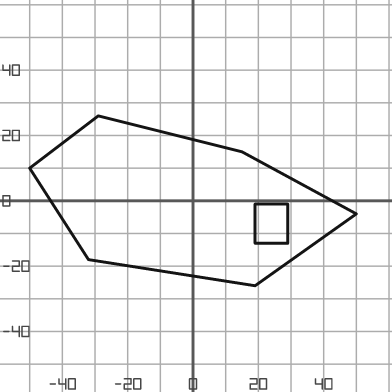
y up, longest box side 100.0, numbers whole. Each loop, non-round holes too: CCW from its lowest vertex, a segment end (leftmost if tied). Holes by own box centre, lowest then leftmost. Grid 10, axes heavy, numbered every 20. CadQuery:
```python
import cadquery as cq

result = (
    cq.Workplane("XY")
    .moveTo(19.0, -26.0)
    .lineTo(50.0, -4.0)
    .lineTo(15.0, 15.0)
    .lineTo(-29.0, 26.0)
    .lineTo(-50.0, 10.0)
    .lineTo(-32.0, -18.0)
    .close()
    .moveTo(19.0, -13.0)
    .lineTo(29.0, -13.0)
    .lineTo(29.0, -1.0)
    .lineTo(19.0, -1.0)
    .close()
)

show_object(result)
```